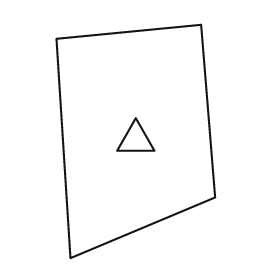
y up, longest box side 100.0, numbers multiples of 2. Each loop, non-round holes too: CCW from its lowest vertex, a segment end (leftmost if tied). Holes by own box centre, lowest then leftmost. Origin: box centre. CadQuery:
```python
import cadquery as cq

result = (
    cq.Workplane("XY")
    .moveTo(-28.0, -50.0)
    .lineTo(34.0, -24.0)
    .lineTo(28.0, 50.0)
    .lineTo(-34.0, 44.0)
    .close()
    .moveTo(-8.0, -4.0)
    .lineTo(8.0, -4.0)
    .lineTo(0.0, 10.0)
    .close()
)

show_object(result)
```